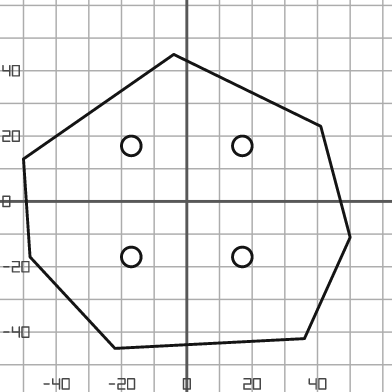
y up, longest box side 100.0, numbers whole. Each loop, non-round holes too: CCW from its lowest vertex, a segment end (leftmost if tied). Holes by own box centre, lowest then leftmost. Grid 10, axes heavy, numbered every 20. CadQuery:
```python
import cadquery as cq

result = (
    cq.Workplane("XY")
    .moveTo(-22.0, -45.0)
    .lineTo(36.0, -42.0)
    .lineTo(50.0, -11.0)
    .lineTo(41.0, 23.0)
    .lineTo(-4.0, 45.0)
    .lineTo(-50.0, 13.0)
    .lineTo(-48.0, -17.0)
    .close()
    .moveTo(-17.0, -17.0)
    .circle(3.0)
    .moveTo(17.0, -17.0)
    .circle(3.0)
    .moveTo(-17.0, 17.0)
    .circle(3.0)
    .moveTo(17.0, 17.0)
    .circle(3.0)
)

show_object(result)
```